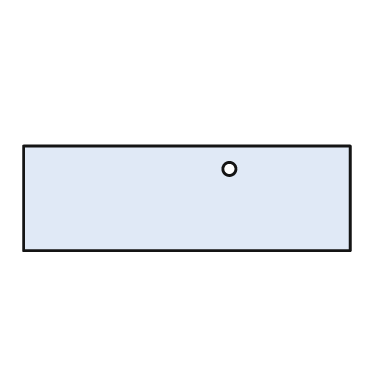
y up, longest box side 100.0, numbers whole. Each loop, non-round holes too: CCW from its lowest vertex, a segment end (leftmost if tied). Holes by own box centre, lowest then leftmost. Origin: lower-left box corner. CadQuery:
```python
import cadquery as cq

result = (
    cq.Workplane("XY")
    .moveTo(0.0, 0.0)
    .lineTo(100.0, 0.0)
    .lineTo(100.0, 32.0)
    .lineTo(0.0, 32.0)
    .close()
    .moveTo(63.0, 25.0)
    .circle(2.0)
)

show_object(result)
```